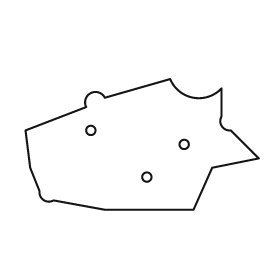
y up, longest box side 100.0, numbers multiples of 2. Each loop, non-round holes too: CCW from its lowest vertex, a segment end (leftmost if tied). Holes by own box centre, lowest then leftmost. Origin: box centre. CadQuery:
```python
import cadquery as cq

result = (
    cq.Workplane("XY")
    .moveTo(-16.0, -28.0)
    .lineTo(22.0, -28.0)
    .lineTo(30.0, -10.0)
    .lineTo(50.0, -6.0)
    .lineTo(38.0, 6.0)
    .threePointArc((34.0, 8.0), (34.0, 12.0))
    .lineTo(34.0, 24.0)
    .threePointArc((22.0, 20.0), (12.0, 28.0))
    .lineTo(-16.0, 20.0)
    .threePointArc((-22.0, 22.0), (-24.0, 16.0))
    .lineTo(-50.0, 6.0)
    .lineTo(-48.0, -10.0)
    .lineTo(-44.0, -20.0)
    .threePointArc((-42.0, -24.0), (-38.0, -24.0))
    .close()
    .moveTo(2.0, -14.0)
    .circle(2.0)
    .moveTo(18.0, 0.0)
    .circle(2.0)
    .moveTo(-22.0, 6.0)
    .circle(2.0)
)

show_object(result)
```